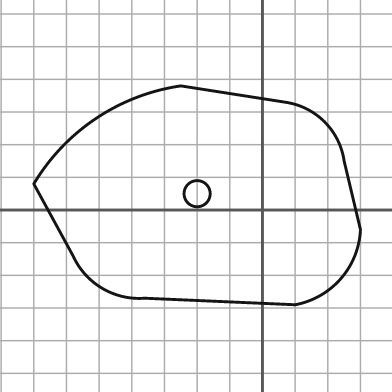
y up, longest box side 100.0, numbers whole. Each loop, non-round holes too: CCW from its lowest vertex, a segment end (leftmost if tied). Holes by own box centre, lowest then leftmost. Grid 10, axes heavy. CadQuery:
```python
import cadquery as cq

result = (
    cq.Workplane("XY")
    .moveTo(10.0, -29.0)
    .threePointArc((24.0, -21.0), (30.0, -6.0))
    .lineTo(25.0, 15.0)
    .threePointArc((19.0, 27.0), (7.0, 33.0))
    .lineTo(-25.0, 38.0)
    .threePointArc((-51.0, 28.0), (-70.0, 8.0))
    .lineTo(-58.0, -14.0)
    .threePointArc((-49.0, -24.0), (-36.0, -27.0))
    .close()
    .moveTo(-20.0, 5.0)
    .circle(4.0)
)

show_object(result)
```